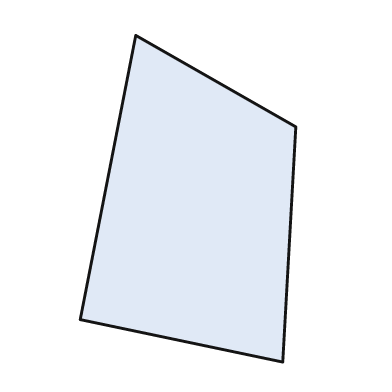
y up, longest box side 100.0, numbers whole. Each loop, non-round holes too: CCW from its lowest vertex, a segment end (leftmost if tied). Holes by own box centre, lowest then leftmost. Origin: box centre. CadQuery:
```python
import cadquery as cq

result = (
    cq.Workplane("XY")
    .moveTo(29.0, -50.0)
    .lineTo(33.0, 22.0)
    .lineTo(-16.0, 50.0)
    .lineTo(-33.0, -37.0)
    .close()
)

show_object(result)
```